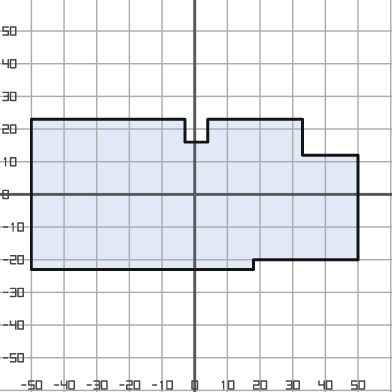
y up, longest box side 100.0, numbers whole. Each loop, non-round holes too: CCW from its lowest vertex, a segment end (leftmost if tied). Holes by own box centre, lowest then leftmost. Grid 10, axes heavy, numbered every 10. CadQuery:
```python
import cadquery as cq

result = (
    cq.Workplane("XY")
    .moveTo(-50.0, -23.0)
    .lineTo(18.0, -23.0)
    .lineTo(18.0, -20.0)
    .lineTo(50.0, -20.0)
    .lineTo(50.0, 12.0)
    .lineTo(33.0, 12.0)
    .lineTo(33.0, 23.0)
    .lineTo(4.0, 23.0)
    .lineTo(4.0, 16.0)
    .lineTo(-3.0, 16.0)
    .lineTo(-3.0, 23.0)
    .lineTo(-50.0, 23.0)
    .close()
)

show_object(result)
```